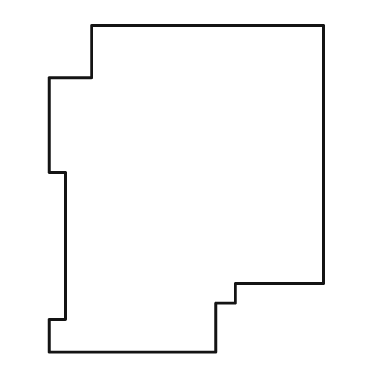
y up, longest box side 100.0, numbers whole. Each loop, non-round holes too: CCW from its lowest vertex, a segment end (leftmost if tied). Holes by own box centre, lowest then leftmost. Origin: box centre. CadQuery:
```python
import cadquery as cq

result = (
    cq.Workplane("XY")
    .moveTo(-42.0, -50.0)
    .lineTo(9.0, -50.0)
    .lineTo(9.0, -35.0)
    .lineTo(15.0, -35.0)
    .lineTo(15.0, -29.0)
    .lineTo(42.0, -29.0)
    .lineTo(42.0, 50.0)
    .lineTo(-29.0, 50.0)
    .lineTo(-29.0, 34.0)
    .lineTo(-42.0, 34.0)
    .lineTo(-42.0, 5.0)
    .lineTo(-37.0, 5.0)
    .lineTo(-37.0, -40.0)
    .lineTo(-42.0, -40.0)
    .close()
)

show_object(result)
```